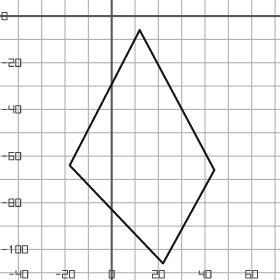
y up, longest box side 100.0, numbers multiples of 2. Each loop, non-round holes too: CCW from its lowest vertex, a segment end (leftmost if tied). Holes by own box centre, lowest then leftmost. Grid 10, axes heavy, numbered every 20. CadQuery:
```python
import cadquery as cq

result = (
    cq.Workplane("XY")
    .moveTo(22.0, -106.0)
    .lineTo(44.0, -66.0)
    .lineTo(12.0, -6.0)
    .lineTo(-18.0, -64.0)
    .close()
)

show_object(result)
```